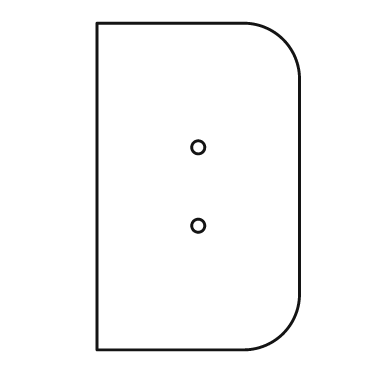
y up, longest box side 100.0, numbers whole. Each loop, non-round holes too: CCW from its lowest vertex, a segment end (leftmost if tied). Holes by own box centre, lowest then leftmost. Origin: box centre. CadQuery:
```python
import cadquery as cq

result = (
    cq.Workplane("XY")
    .moveTo(-31.0, -50.0)
    .lineTo(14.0, -50.0)
    .threePointArc((26.0, -45.0), (31.0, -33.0))
    .lineTo(31.0, 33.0)
    .threePointArc((26.0, 45.0), (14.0, 50.0))
    .lineTo(-31.0, 50.0)
    .close()
    .moveTo(0.0, -12.0)
    .circle(2.0)
    .moveTo(0.0, 12.0)
    .circle(2.0)
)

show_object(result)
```